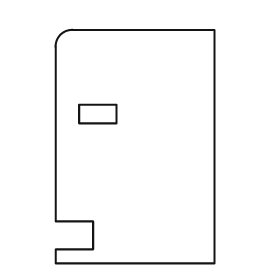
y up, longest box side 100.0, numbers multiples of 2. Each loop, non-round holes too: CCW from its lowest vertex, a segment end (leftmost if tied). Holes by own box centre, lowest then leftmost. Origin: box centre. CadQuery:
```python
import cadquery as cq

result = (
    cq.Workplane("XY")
    .moveTo(-34.0, -50.0)
    .lineTo(34.0, -50.0)
    .lineTo(34.0, 50.0)
    .lineTo(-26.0, 50.0)
    .threePointArc((-32.0, 48.0), (-34.0, 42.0))
    .lineTo(-34.0, -32.0)
    .lineTo(-18.0, -32.0)
    .lineTo(-18.0, -44.0)
    .lineTo(-34.0, -44.0)
    .close()
    .moveTo(-24.0, 10.0)
    .lineTo(-8.0, 10.0)
    .lineTo(-8.0, 18.0)
    .lineTo(-24.0, 18.0)
    .close()
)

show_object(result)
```